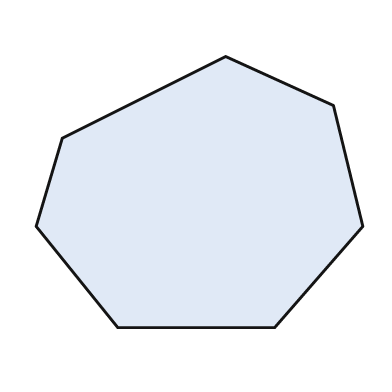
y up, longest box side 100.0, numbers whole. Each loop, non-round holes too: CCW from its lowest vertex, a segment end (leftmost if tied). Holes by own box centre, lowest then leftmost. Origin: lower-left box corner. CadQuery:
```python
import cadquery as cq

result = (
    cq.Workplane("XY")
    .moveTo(25.0, 0.0)
    .lineTo(73.0, 0.0)
    .lineTo(100.0, 31.0)
    .lineTo(91.0, 68.0)
    .lineTo(58.0, 83.0)
    .lineTo(8.0, 58.0)
    .lineTo(0.0, 31.0)
    .close()
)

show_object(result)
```